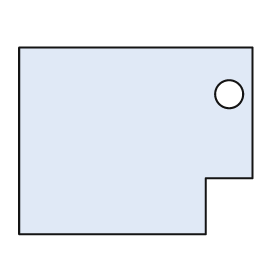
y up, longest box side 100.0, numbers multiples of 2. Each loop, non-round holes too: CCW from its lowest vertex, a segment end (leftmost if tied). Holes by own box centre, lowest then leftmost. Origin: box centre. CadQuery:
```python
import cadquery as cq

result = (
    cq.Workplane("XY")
    .moveTo(-50.0, -40.0)
    .lineTo(30.0, -40.0)
    .lineTo(30.0, -16.0)
    .lineTo(50.0, -16.0)
    .lineTo(50.0, 40.0)
    .lineTo(-50.0, 40.0)
    .close()
    .moveTo(40.0, 20.0)
    .circle(6.0)
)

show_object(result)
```